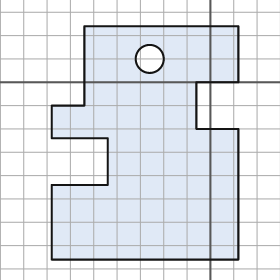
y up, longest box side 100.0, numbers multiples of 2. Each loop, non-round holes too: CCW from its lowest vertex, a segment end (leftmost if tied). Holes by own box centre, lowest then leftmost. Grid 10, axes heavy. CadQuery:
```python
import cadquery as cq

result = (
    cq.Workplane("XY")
    .moveTo(-68.0, -76.0)
    .lineTo(12.0, -76.0)
    .lineTo(12.0, -20.0)
    .lineTo(-6.0, -20.0)
    .lineTo(-6.0, 0.0)
    .lineTo(12.0, 0.0)
    .lineTo(12.0, 24.0)
    .lineTo(-54.0, 24.0)
    .lineTo(-54.0, -10.0)
    .lineTo(-68.0, -10.0)
    .lineTo(-68.0, -24.0)
    .lineTo(-44.0, -24.0)
    .lineTo(-44.0, -44.0)
    .lineTo(-68.0, -44.0)
    .close()
    .moveTo(-26.0, 10.0)
    .circle(6.0)
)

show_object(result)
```